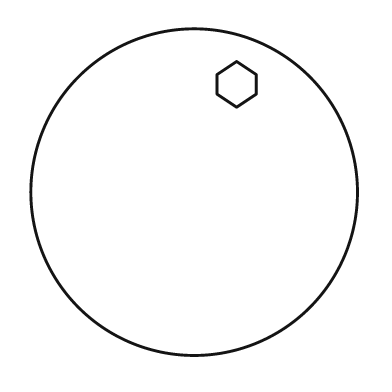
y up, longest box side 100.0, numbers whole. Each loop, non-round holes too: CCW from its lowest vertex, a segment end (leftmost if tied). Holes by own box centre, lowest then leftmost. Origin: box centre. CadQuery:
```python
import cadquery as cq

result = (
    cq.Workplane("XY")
    .moveTo(0.0, 0.0)
    .circle(50.0)
    .moveTo(13.0, 26.0)
    .lineTo(19.0, 30.0)
    .lineTo(19.0, 36.0)
    .lineTo(13.0, 40.0)
    .lineTo(7.0, 36.0)
    .lineTo(7.0, 30.0)
    .close()
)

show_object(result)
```